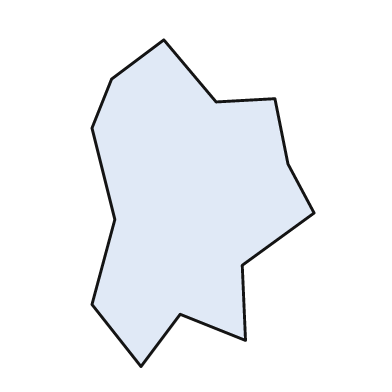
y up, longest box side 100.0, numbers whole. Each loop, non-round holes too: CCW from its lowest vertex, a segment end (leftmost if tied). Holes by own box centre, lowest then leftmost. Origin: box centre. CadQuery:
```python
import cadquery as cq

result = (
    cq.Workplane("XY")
    .moveTo(-19.0, -50.0)
    .lineTo(-7.0, -34.0)
    .lineTo(13.0, -42.0)
    .lineTo(12.0, -19.0)
    .lineTo(34.0, -3.0)
    .lineTo(26.0, 12.0)
    .lineTo(22.0, 32.0)
    .lineTo(4.0, 31.0)
    .lineTo(-12.0, 50.0)
    .lineTo(-28.0, 38.0)
    .lineTo(-34.0, 23.0)
    .lineTo(-27.0, -5.0)
    .lineTo(-34.0, -31.0)
    .close()
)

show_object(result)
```